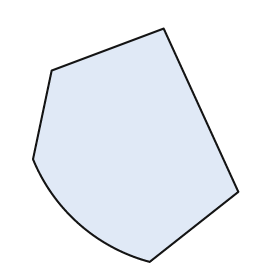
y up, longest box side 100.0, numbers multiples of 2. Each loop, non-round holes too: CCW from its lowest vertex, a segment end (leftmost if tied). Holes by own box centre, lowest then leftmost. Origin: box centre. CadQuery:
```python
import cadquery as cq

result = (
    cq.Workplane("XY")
    .moveTo(6.0, -50.0)
    .lineTo(44.0, -20.0)
    .lineTo(12.0, 50.0)
    .lineTo(-36.0, 32.0)
    .lineTo(-44.0, -6.0)
    .threePointArc((-24.0, -34.0), (6.0, -50.0))
    .close()
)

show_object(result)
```